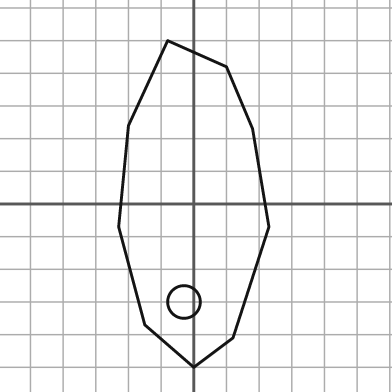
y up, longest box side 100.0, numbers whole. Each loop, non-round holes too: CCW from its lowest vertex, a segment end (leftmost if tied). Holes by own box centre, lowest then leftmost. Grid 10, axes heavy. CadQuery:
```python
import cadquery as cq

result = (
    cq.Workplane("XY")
    .moveTo(0.0, -50.0)
    .lineTo(12.0, -41.0)
    .lineTo(23.0, -7.0)
    .lineTo(18.0, 23.0)
    .lineTo(10.0, 42.0)
    .lineTo(-8.0, 50.0)
    .lineTo(-20.0, 24.0)
    .lineTo(-23.0, -7.0)
    .lineTo(-15.0, -37.0)
    .close()
    .moveTo(-3.0, -30.0)
    .circle(5.0)
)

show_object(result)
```